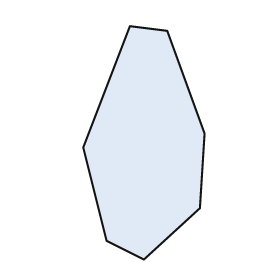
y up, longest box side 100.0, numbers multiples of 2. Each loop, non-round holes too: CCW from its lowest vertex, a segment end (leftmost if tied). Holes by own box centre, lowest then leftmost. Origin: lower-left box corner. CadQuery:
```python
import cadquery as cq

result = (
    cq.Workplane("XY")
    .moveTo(26.0, 0.0)
    .lineTo(50.0, 22.0)
    .lineTo(52.0, 54.0)
    .lineTo(36.0, 98.0)
    .lineTo(20.0, 100.0)
    .lineTo(0.0, 48.0)
    .lineTo(10.0, 8.0)
    .close()
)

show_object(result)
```